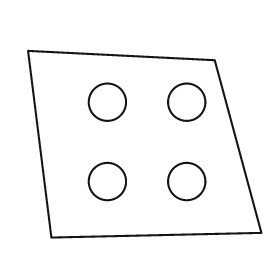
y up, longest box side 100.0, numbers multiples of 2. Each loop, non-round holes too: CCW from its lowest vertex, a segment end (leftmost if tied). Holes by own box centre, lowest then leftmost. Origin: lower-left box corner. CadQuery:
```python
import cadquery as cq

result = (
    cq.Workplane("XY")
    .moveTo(10.0, 0.0)
    .lineTo(100.0, 2.0)
    .lineTo(80.0, 76.0)
    .lineTo(0.0, 80.0)
    .close()
    .moveTo(34.0, 24.0)
    .circle(8.0)
    .moveTo(68.0, 24.0)
    .circle(8.0)
    .moveTo(34.0, 58.0)
    .circle(8.0)
    .moveTo(68.0, 58.0)
    .circle(8.0)
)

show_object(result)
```